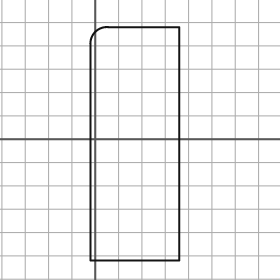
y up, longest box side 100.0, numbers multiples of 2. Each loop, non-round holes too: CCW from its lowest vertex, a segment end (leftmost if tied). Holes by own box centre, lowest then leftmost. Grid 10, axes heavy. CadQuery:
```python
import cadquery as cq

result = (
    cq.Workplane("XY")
    .moveTo(-2.0, -52.0)
    .lineTo(36.0, -52.0)
    .lineTo(36.0, 48.0)
    .lineTo(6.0, 48.0)
    .threePointArc((0.0, 46.0), (-2.0, 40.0))
    .close()
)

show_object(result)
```